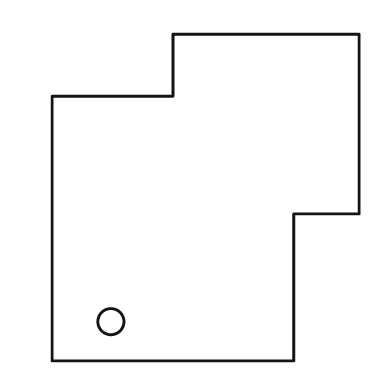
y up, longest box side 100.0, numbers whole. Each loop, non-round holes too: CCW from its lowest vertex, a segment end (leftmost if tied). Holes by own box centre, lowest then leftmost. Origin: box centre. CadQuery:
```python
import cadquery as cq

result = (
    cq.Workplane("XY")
    .moveTo(-47.0, -50.0)
    .lineTo(27.0, -50.0)
    .lineTo(27.0, -5.0)
    .lineTo(47.0, -5.0)
    .lineTo(47.0, 50.0)
    .lineTo(-10.0, 50.0)
    .lineTo(-10.0, 31.0)
    .lineTo(-47.0, 31.0)
    .close()
    .moveTo(-29.0, -38.0)
    .circle(4.0)
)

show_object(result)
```